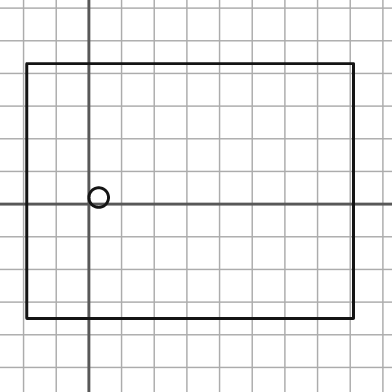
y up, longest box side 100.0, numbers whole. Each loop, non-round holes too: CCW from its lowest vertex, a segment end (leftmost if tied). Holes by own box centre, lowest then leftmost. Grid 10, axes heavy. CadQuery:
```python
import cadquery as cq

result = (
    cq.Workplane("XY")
    .moveTo(-19.0, -35.0)
    .lineTo(81.0, -35.0)
    .lineTo(81.0, 43.0)
    .lineTo(-19.0, 43.0)
    .close()
    .moveTo(3.0, 2.0)
    .circle(3.0)
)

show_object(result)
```